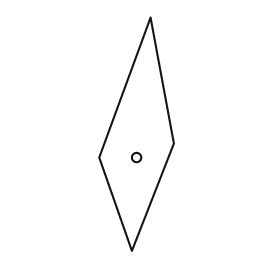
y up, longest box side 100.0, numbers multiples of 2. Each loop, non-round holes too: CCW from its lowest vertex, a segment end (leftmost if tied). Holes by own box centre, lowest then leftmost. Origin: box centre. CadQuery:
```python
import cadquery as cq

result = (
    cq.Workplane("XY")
    .moveTo(-2.0, -50.0)
    .lineTo(16.0, -4.0)
    .lineTo(6.0, 50.0)
    .lineTo(-16.0, -10.0)
    .close()
    .moveTo(0.0, -10.0)
    .circle(2.0)
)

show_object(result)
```